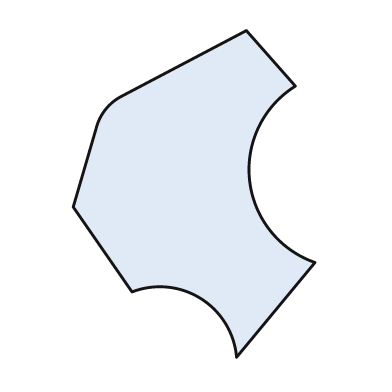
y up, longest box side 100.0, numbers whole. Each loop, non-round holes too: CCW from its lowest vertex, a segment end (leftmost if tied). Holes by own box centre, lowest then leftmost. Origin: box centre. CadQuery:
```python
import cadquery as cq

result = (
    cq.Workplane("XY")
    .moveTo(13.0, -50.0)
    .lineTo(37.0, -21.0)
    .threePointArc((17.0, 4.0), (31.0, 33.0))
    .lineTo(16.0, 50.0)
    .lineTo(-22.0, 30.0)
    .threePointArc((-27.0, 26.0), (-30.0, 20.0))
    .lineTo(-37.0, -4.0)
    .lineTo(-19.0, -30.0)
    .threePointArc((2.0, -32.0), (13.0, -50.0))
    .close()
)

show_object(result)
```